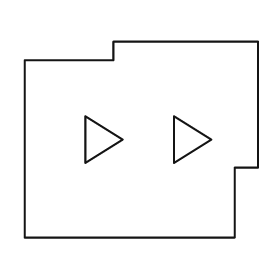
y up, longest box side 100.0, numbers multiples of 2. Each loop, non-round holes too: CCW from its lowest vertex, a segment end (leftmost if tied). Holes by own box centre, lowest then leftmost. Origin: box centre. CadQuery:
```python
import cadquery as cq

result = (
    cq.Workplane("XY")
    .moveTo(-50.0, -42.0)
    .lineTo(40.0, -42.0)
    .lineTo(40.0, -12.0)
    .lineTo(50.0, -12.0)
    .lineTo(50.0, 42.0)
    .lineTo(-12.0, 42.0)
    .lineTo(-12.0, 34.0)
    .lineTo(-50.0, 34.0)
    .close()
    .moveTo(-24.0, -10.0)
    .lineTo(-8.0, 0.0)
    .lineTo(-24.0, 10.0)
    .close()
    .moveTo(14.0, -10.0)
    .lineTo(30.0, 0.0)
    .lineTo(14.0, 10.0)
    .close()
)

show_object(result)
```